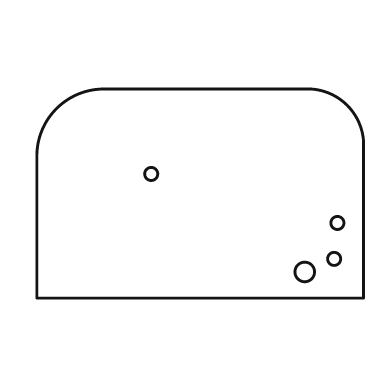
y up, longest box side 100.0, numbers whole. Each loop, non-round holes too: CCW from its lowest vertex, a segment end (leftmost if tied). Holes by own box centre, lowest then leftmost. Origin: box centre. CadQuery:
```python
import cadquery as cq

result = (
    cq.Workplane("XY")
    .moveTo(-50.0, -32.0)
    .lineTo(50.0, -32.0)
    .lineTo(50.0, 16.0)
    .threePointArc((45.0, 27.0), (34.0, 32.0))
    .lineTo(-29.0, 32.0)
    .threePointArc((-44.0, 26.0), (-50.0, 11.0))
    .close()
    .moveTo(32.0, -24.0)
    .circle(3.0)
    .moveTo(41.0, -20.0)
    .circle(2.0)
    .moveTo(42.0, -9.0)
    .circle(2.0)
    .moveTo(-15.0, 6.0)
    .circle(2.0)
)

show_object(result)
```